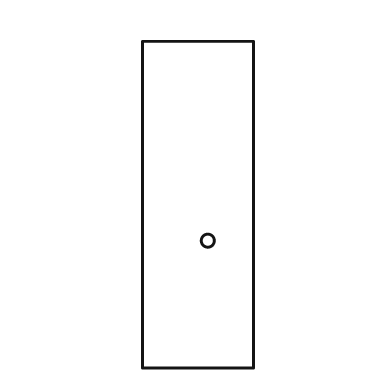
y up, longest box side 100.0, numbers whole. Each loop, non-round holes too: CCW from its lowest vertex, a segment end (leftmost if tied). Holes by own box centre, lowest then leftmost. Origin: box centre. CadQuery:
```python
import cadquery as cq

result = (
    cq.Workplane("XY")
    .moveTo(-17.0, -50.0)
    .lineTo(17.0, -50.0)
    .lineTo(17.0, 50.0)
    .lineTo(-17.0, 50.0)
    .close()
    .moveTo(3.0, -11.0)
    .circle(2.0)
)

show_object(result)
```